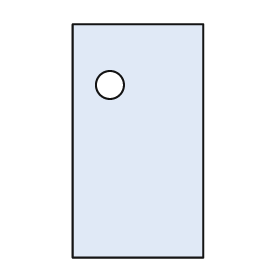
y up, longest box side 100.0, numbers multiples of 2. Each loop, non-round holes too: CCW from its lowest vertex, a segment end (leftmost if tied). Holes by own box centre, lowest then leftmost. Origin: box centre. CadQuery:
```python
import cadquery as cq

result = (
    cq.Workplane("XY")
    .moveTo(-28.0, -50.0)
    .lineTo(28.0, -50.0)
    .lineTo(28.0, 50.0)
    .lineTo(-28.0, 50.0)
    .close()
    .moveTo(-12.0, 24.0)
    .circle(6.0)
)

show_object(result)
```